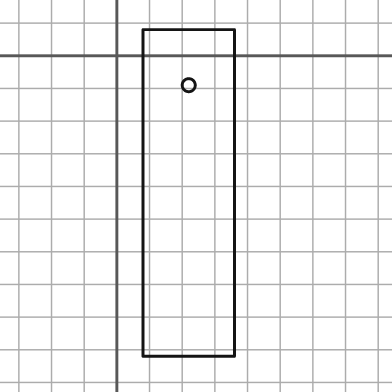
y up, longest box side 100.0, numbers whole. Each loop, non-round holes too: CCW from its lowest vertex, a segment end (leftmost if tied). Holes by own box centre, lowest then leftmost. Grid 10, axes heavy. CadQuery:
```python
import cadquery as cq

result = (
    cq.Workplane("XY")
    .moveTo(8.0, -92.0)
    .lineTo(36.0, -92.0)
    .lineTo(36.0, 8.0)
    .lineTo(8.0, 8.0)
    .close()
    .moveTo(22.0, -9.0)
    .circle(2.0)
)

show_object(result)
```